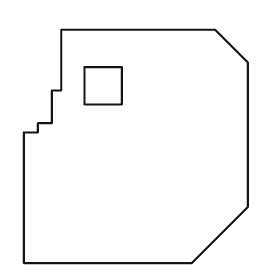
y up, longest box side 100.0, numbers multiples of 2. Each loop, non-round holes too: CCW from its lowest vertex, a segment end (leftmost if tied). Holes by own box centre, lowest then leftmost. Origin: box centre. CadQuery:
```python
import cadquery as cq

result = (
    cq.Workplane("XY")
    .moveTo(-48.0, -50.0)
    .lineTo(24.0, -50.0)
    .lineTo(48.0, -26.0)
    .lineTo(48.0, 36.0)
    .lineTo(34.0, 50.0)
    .lineTo(-32.0, 50.0)
    .lineTo(-32.0, 24.0)
    .lineTo(-36.0, 24.0)
    .lineTo(-36.0, 10.0)
    .lineTo(-42.0, 10.0)
    .lineTo(-42.0, 6.0)
    .lineTo(-48.0, 6.0)
    .close()
    .moveTo(-22.0, 18.0)
    .lineTo(-6.0, 18.0)
    .lineTo(-6.0, 34.0)
    .lineTo(-22.0, 34.0)
    .close()
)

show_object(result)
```